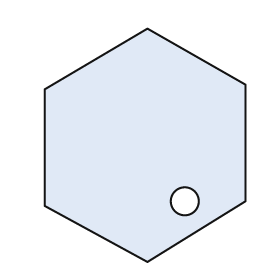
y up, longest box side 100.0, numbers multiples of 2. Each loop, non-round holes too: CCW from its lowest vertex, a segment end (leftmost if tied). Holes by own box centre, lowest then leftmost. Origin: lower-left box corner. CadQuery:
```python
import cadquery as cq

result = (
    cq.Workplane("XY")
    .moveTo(44.0, 0.0)
    .lineTo(86.0, 26.0)
    .lineTo(86.0, 76.0)
    .lineTo(44.0, 100.0)
    .lineTo(0.0, 74.0)
    .lineTo(0.0, 24.0)
    .close()
    .moveTo(60.0, 26.0)
    .circle(6.0)
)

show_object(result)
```